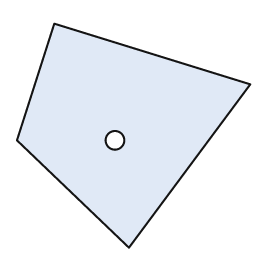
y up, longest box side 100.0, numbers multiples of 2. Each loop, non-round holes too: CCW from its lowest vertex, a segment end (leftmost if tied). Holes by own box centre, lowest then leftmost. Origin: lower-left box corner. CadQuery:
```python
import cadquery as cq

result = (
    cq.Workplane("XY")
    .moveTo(48.0, 0.0)
    .lineTo(100.0, 70.0)
    .lineTo(16.0, 96.0)
    .lineTo(0.0, 46.0)
    .close()
    .moveTo(42.0, 46.0)
    .circle(4.0)
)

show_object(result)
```